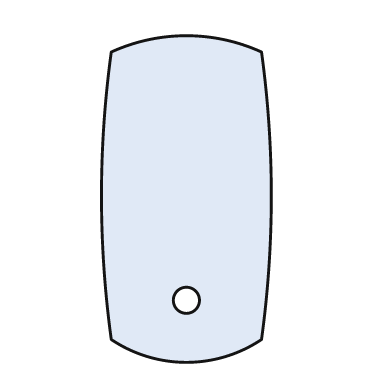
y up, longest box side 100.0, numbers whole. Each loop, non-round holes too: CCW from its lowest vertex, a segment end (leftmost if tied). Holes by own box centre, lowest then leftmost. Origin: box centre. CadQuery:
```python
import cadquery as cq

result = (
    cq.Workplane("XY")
    .moveTo(-23.0, -43.0)
    .threePointArc((0.0, -50.0), (23.0, -43.0))
    .threePointArc((26.0, 1.0), (23.0, 45.0))
    .threePointArc((0.0, 50.0), (-23.0, 45.0))
    .threePointArc((-26.0, 1.0), (-23.0, -43.0))
    .close()
    .moveTo(0.0, -31.0)
    .circle(4.0)
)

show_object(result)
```